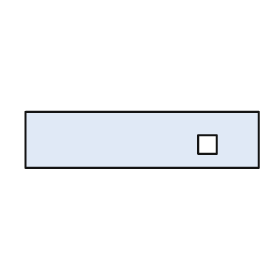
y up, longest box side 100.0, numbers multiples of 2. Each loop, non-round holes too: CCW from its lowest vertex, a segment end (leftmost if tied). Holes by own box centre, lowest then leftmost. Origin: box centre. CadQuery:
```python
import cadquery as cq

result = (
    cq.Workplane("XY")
    .moveTo(-50.0, -12.0)
    .lineTo(50.0, -12.0)
    .lineTo(50.0, 12.0)
    .lineTo(-50.0, 12.0)
    .close()
    .moveTo(24.0, -6.0)
    .lineTo(32.0, -6.0)
    .lineTo(32.0, 2.0)
    .lineTo(24.0, 2.0)
    .close()
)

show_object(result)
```